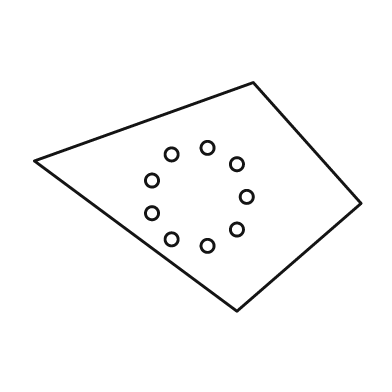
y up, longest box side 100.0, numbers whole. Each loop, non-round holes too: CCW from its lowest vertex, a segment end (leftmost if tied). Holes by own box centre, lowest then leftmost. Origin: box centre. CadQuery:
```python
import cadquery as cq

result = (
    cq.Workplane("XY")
    .moveTo(12.0, -35.0)
    .lineTo(50.0, -2.0)
    .lineTo(17.0, 35.0)
    .lineTo(-50.0, 11.0)
    .close()
    .moveTo(3.0, -15.0)
    .circle(2.0)
    .moveTo(-8.0, -13.0)
    .circle(2.0)
    .moveTo(12.0, -10.0)
    .circle(2.0)
    .moveTo(-14.0, -5.0)
    .circle(2.0)
    .moveTo(15.0, 0.0)
    .circle(2.0)
    .moveTo(-14.0, 5.0)
    .circle(2.0)
    .moveTo(12.0, 10.0)
    .circle(2.0)
    .moveTo(-8.0, 13.0)
    .circle(2.0)
    .moveTo(3.0, 15.0)
    .circle(2.0)
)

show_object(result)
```